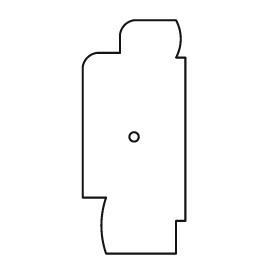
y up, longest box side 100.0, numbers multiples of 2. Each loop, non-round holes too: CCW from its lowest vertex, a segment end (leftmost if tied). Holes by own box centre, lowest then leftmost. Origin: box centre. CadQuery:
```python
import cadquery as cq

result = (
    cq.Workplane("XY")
    .moveTo(-12.0, -50.0)
    .lineTo(18.0, -50.0)
    .lineTo(18.0, -36.0)
    .lineTo(22.0, -36.0)
    .lineTo(22.0, 34.0)
    .lineTo(18.0, 34.0)
    .threePointArc((20.0, 42.0), (18.0, 50.0))
    .lineTo(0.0, 50.0)
    .threePointArc((-4.0, 48.0), (-6.0, 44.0))
    .lineTo(-6.0, 36.0)
    .lineTo(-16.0, 36.0)
    .threePointArc((-20.0, 34.0), (-22.0, 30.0))
    .lineTo(-22.0, -26.0)
    .lineTo(-12.0, -26.0)
    .threePointArc((-14.0, -38.0), (-12.0, -50.0))
    .close()
    .moveTo(0.0, 0.0)
    .circle(2.0)
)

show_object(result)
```